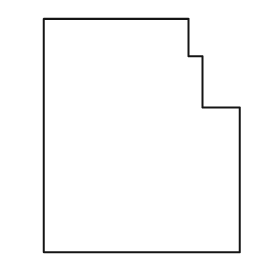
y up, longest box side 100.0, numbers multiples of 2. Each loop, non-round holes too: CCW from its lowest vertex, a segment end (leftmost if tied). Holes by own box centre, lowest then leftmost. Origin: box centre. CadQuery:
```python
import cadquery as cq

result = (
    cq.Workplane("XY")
    .moveTo(-42.0, -50.0)
    .lineTo(42.0, -50.0)
    .lineTo(42.0, 12.0)
    .lineTo(26.0, 12.0)
    .lineTo(26.0, 34.0)
    .lineTo(20.0, 34.0)
    .lineTo(20.0, 50.0)
    .lineTo(-42.0, 50.0)
    .close()
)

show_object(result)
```